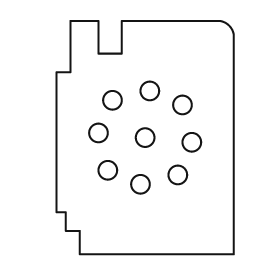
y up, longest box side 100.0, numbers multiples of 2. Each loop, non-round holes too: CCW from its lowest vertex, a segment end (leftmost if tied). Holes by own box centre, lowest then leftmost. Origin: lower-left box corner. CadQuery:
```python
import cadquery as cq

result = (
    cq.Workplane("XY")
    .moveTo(10.0, 0.0)
    .lineTo(76.0, 0.0)
    .lineTo(76.0, 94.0)
    .threePointArc((74.0, 98.0), (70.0, 100.0))
    .lineTo(28.0, 100.0)
    .lineTo(28.0, 86.0)
    .lineTo(18.0, 86.0)
    .lineTo(18.0, 100.0)
    .lineTo(6.0, 100.0)
    .lineTo(6.0, 78.0)
    .lineTo(0.0, 78.0)
    .lineTo(0.0, 18.0)
    .lineTo(4.0, 18.0)
    .lineTo(4.0, 10.0)
    .lineTo(10.0, 10.0)
    .close()
    .moveTo(36.0, 30.0)
    .circle(4.0)
    .moveTo(52.0, 34.0)
    .circle(4.0)
    .moveTo(22.0, 36.0)
    .circle(4.0)
    .moveTo(58.0, 48.0)
    .circle(4.0)
    .moveTo(38.0, 50.0)
    .circle(4.0)
    .moveTo(18.0, 52.0)
    .circle(4.0)
    .moveTo(54.0, 64.0)
    .circle(4.0)
    .moveTo(24.0, 66.0)
    .circle(4.0)
    .moveTo(40.0, 70.0)
    .circle(4.0)
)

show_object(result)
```